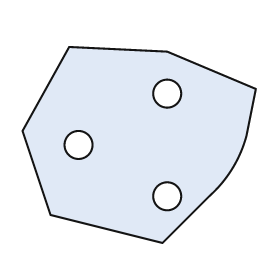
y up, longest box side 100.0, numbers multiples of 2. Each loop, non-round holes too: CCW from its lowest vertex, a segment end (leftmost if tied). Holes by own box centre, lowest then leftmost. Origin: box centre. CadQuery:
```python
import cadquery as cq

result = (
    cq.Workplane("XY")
    .moveTo(10.0, -42.0)
    .lineTo(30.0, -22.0)
    .threePointArc((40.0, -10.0), (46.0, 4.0))
    .lineTo(50.0, 24.0)
    .lineTo(12.0, 40.0)
    .lineTo(-30.0, 42.0)
    .lineTo(-50.0, 6.0)
    .lineTo(-38.0, -30.0)
    .close()
    .moveTo(12.0, -22.0)
    .circle(6.0)
    .moveTo(-26.0, 0.0)
    .circle(6.0)
    .moveTo(12.0, 22.0)
    .circle(6.0)
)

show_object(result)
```